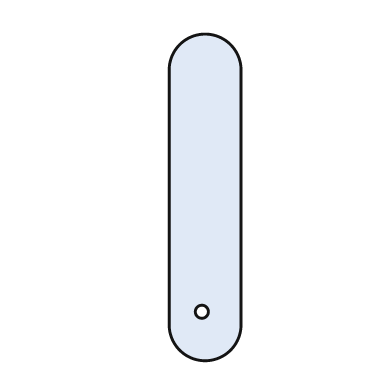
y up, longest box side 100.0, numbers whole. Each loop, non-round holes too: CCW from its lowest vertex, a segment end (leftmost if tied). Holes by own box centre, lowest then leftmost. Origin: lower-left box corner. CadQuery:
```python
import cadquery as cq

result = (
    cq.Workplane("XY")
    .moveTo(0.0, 11.0)
    .threePointArc((11.0, 0.0), (22.0, 11.0))
    .lineTo(22.0, 89.0)
    .threePointArc((11.0, 100.0), (0.0, 89.0))
    .close()
    .moveTo(10.0, 15.0)
    .circle(2.0)
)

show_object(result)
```